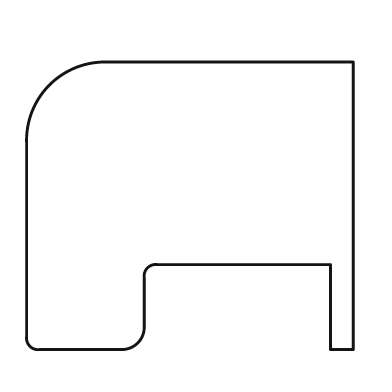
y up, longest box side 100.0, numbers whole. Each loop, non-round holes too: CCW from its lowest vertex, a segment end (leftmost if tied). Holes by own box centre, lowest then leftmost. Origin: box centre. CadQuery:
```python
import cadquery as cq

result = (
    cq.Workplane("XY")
    .moveTo(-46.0, -44.0)
    .lineTo(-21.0, -44.0)
    .threePointArc((-16.0, -42.0), (-14.0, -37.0))
    .lineTo(-14.0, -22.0)
    .threePointArc((-13.0, -19.0), (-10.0, -18.0))
    .lineTo(43.0, -18.0)
    .lineTo(43.0, -44.0)
    .lineTo(50.0, -44.0)
    .lineTo(50.0, 44.0)
    .lineTo(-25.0, 44.0)
    .threePointArc((-43.0, 37.0), (-50.0, 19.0))
    .lineTo(-50.0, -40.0)
    .threePointArc((-49.0, -43.0), (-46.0, -44.0))
    .close()
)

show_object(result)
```